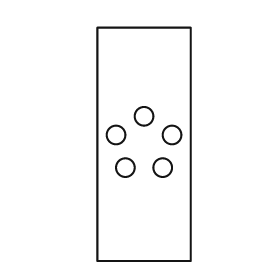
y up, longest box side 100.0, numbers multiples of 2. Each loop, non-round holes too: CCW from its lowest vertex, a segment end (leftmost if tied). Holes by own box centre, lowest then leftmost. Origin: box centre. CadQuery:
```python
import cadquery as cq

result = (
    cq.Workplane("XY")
    .moveTo(-20.0, -50.0)
    .lineTo(20.0, -50.0)
    .lineTo(20.0, 50.0)
    .lineTo(-20.0, 50.0)
    .close()
    .moveTo(-8.0, -10.0)
    .circle(4.0)
    .moveTo(8.0, -10.0)
    .circle(4.0)
    .moveTo(-12.0, 4.0)
    .circle(4.0)
    .moveTo(12.0, 4.0)
    .circle(4.0)
    .moveTo(0.0, 12.0)
    .circle(4.0)
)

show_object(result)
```